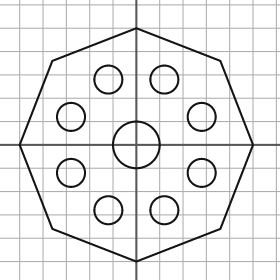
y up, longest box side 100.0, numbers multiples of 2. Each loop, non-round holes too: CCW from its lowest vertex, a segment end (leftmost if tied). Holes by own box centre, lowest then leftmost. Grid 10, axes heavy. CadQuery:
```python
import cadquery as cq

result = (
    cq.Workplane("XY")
    .moveTo(0.0, -50.0)
    .lineTo(36.0, -36.0)
    .lineTo(50.0, 0.0)
    .lineTo(36.0, 36.0)
    .lineTo(0.0, 50.0)
    .lineTo(-36.0, 36.0)
    .lineTo(-50.0, 0.0)
    .lineTo(-36.0, -36.0)
    .close()
    .moveTo(-12.0, -28.0)
    .circle(6.0)
    .moveTo(12.0, -28.0)
    .circle(6.0)
    .moveTo(-28.0, -12.0)
    .circle(6.0)
    .moveTo(28.0, -12.0)
    .circle(6.0)
    .moveTo(0.0, 0.0)
    .circle(10.0)
    .moveTo(-28.0, 12.0)
    .circle(6.0)
    .moveTo(28.0, 12.0)
    .circle(6.0)
    .moveTo(-12.0, 28.0)
    .circle(6.0)
    .moveTo(12.0, 28.0)
    .circle(6.0)
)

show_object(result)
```